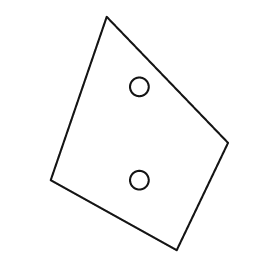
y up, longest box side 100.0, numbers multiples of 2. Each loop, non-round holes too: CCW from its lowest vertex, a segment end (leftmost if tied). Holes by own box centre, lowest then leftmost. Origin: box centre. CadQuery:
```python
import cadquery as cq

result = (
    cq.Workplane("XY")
    .moveTo(16.0, -50.0)
    .lineTo(38.0, -4.0)
    .lineTo(-14.0, 50.0)
    .lineTo(-38.0, -20.0)
    .close()
    .moveTo(0.0, -20.0)
    .circle(4.0)
    .moveTo(0.0, 20.0)
    .circle(4.0)
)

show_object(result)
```